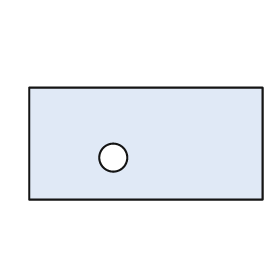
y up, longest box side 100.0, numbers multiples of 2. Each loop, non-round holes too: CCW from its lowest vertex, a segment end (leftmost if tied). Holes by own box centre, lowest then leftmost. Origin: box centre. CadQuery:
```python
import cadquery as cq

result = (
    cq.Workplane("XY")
    .moveTo(-50.0, -24.0)
    .lineTo(50.0, -24.0)
    .lineTo(50.0, 24.0)
    .lineTo(-50.0, 24.0)
    .close()
    .moveTo(-14.0, -6.0)
    .circle(6.0)
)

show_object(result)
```